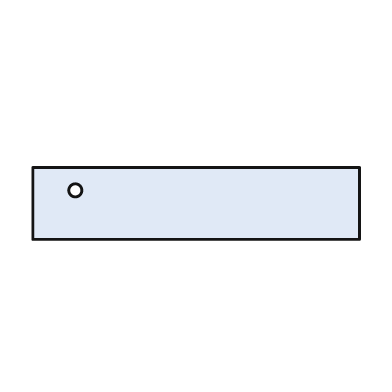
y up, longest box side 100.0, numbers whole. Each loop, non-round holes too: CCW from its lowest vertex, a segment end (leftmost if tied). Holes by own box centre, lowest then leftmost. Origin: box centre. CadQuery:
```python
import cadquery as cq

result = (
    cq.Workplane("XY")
    .moveTo(-50.0, -11.0)
    .lineTo(50.0, -11.0)
    .lineTo(50.0, 11.0)
    .lineTo(-50.0, 11.0)
    .close()
    .moveTo(-37.0, 4.0)
    .circle(2.0)
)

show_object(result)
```